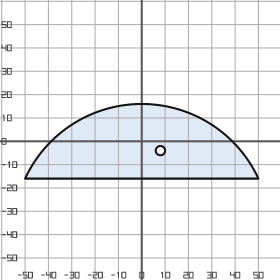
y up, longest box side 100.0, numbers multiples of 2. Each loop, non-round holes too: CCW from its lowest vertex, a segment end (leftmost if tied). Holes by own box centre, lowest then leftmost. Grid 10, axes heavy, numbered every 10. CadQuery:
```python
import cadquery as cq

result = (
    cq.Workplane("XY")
    .moveTo(-50.0, -16.0)
    .lineTo(50.0, -16.0)
    .threePointArc((0.0, 16.0), (-50.0, -16.0))
    .close()
    .moveTo(8.0, -4.0)
    .circle(2.0)
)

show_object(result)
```